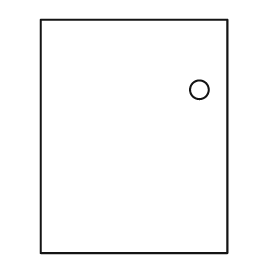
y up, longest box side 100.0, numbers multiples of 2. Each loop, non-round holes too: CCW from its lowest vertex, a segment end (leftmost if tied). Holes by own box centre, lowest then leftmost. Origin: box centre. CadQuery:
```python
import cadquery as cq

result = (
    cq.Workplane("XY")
    .moveTo(-40.0, -50.0)
    .lineTo(40.0, -50.0)
    .lineTo(40.0, 50.0)
    .lineTo(-40.0, 50.0)
    .close()
    .moveTo(28.0, 20.0)
    .circle(4.0)
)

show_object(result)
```